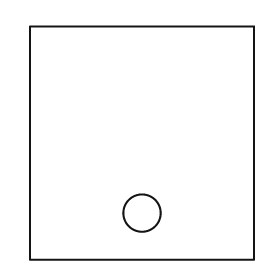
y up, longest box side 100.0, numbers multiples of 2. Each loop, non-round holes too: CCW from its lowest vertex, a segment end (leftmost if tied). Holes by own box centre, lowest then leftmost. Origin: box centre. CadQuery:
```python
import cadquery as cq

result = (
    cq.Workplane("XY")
    .moveTo(-48.0, -50.0)
    .lineTo(48.0, -50.0)
    .lineTo(48.0, 50.0)
    .lineTo(-48.0, 50.0)
    .close()
    .moveTo(0.0, -30.0)
    .circle(8.0)
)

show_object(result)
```